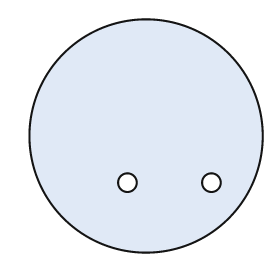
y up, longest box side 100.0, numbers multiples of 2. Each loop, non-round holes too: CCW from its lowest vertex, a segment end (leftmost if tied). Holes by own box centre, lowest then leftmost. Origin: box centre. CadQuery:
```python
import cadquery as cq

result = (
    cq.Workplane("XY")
    .moveTo(0.0, 0.0)
    .circle(50.0)
    .moveTo(-8.0, -20.0)
    .circle(4.0)
    .moveTo(28.0, -20.0)
    .circle(4.0)
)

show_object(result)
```